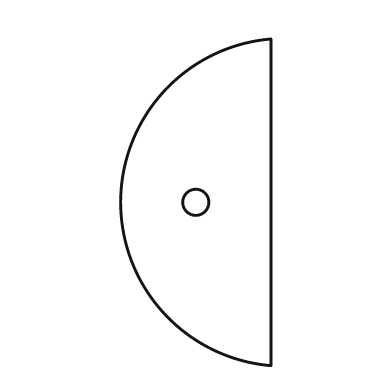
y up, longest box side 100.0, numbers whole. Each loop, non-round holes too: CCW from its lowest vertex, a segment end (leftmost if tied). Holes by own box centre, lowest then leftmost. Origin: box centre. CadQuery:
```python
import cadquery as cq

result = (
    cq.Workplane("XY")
    .moveTo(23.0, -50.0)
    .lineTo(23.0, 50.0)
    .threePointArc((-23.0, 0.0), (23.0, -50.0))
    .close()
    .moveTo(0.0, 0.0)
    .circle(4.0)
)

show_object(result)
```